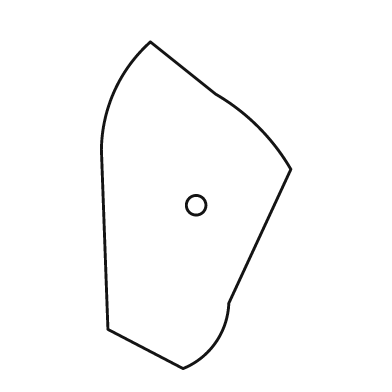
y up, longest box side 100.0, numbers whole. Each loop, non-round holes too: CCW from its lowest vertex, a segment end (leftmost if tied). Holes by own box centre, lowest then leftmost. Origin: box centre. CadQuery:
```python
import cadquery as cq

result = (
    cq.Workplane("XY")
    .moveTo(-4.0, -50.0)
    .threePointArc((6.0, -42.0), (10.0, -30.0))
    .lineTo(29.0, 11.0)
    .threePointArc((19.0, 24.0), (6.0, 34.0))
    .lineTo(-14.0, 50.0)
    .threePointArc((-25.0, 35.0), (-29.0, 17.0))
    .lineTo(-27.0, -38.0)
    .close()
    .moveTo(0.0, 0.0)
    .circle(3.0)
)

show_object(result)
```